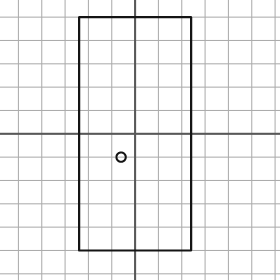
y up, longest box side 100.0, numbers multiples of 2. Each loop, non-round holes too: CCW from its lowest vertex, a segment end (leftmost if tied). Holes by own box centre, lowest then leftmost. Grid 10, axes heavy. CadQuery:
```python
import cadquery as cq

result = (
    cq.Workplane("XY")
    .moveTo(-24.0, -50.0)
    .lineTo(24.0, -50.0)
    .lineTo(24.0, 50.0)
    .lineTo(-24.0, 50.0)
    .close()
    .moveTo(-6.0, -10.0)
    .circle(2.0)
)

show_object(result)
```